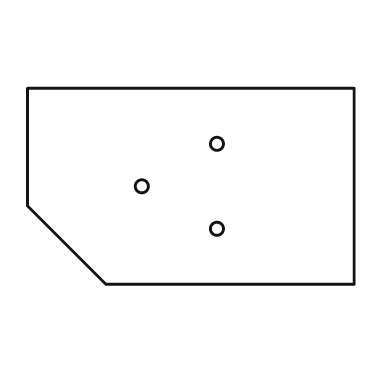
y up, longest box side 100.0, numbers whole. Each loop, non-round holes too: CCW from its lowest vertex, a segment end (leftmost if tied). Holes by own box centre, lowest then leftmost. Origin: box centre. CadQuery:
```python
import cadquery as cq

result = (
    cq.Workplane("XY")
    .moveTo(-26.0, -30.0)
    .lineTo(50.0, -30.0)
    .lineTo(50.0, 30.0)
    .lineTo(-50.0, 30.0)
    .lineTo(-50.0, -6.0)
    .close()
    .moveTo(8.0, -13.0)
    .circle(2.0)
    .moveTo(-15.0, 0.0)
    .circle(2.0)
    .moveTo(8.0, 13.0)
    .circle(2.0)
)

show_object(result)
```